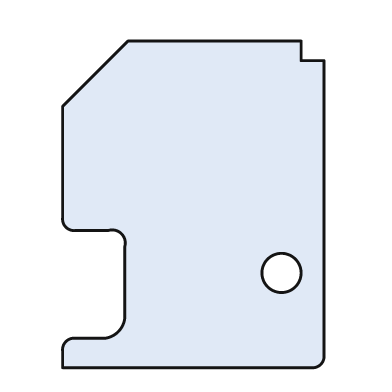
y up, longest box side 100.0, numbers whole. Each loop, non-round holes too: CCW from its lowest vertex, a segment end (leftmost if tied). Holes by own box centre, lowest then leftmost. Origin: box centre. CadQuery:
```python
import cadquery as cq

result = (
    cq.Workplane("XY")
    .moveTo(-40.0, -50.0)
    .lineTo(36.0, -50.0)
    .threePointArc((39.0, -49.0), (40.0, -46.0))
    .lineTo(40.0, 44.0)
    .lineTo(33.0, 44.0)
    .lineTo(33.0, 50.0)
    .lineTo(-20.0, 50.0)
    .lineTo(-40.0, 30.0)
    .lineTo(-40.0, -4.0)
    .threePointArc((-39.0, -7.0), (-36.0, -8.0))
    .lineTo(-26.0, -8.0)
    .threePointArc((-22.0, -9.0), (-21.0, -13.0))
    .lineTo(-21.0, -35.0)
    .threePointArc((-23.0, -39.0), (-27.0, -41.0))
    .lineTo(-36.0, -41.0)
    .threePointArc((-39.0, -42.0), (-40.0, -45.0))
    .close()
    .moveTo(27.0, -21.0)
    .circle(6.0)
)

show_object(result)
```